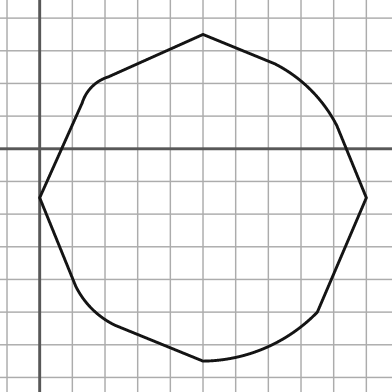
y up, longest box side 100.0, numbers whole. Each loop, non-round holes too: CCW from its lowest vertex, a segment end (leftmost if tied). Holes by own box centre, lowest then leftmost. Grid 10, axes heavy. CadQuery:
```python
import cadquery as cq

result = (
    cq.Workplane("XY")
    .moveTo(50.0, -65.0)
    .threePointArc((69.0, -61.0), (85.0, -50.0))
    .lineTo(100.0, -15.0)
    .lineTo(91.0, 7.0)
    .threePointArc((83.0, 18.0), (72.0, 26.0))
    .lineTo(50.0, 35.0)
    .lineTo(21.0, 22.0)
    .threePointArc((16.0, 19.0), (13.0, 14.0))
    .lineTo(0.0, -15.0)
    .lineTo(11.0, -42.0)
    .threePointArc((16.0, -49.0), (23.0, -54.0))
    .close()
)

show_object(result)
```